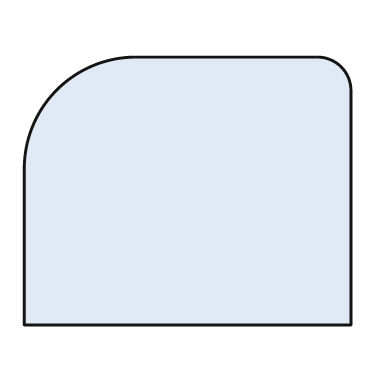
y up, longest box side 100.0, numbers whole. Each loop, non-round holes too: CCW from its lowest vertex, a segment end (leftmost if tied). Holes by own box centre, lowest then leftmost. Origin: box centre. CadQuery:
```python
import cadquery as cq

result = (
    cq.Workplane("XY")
    .moveTo(-50.0, -41.0)
    .lineTo(50.0, -41.0)
    .lineTo(50.0, 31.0)
    .threePointArc((47.0, 38.0), (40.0, 41.0))
    .lineTo(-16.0, 41.0)
    .threePointArc((-40.0, 31.0), (-50.0, 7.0))
    .close()
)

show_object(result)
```